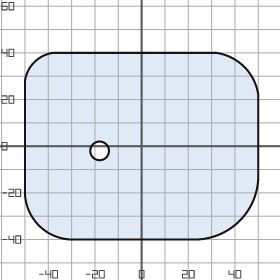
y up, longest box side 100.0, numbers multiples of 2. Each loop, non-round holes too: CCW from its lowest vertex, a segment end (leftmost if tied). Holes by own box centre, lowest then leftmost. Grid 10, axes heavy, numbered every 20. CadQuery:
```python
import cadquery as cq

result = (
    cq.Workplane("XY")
    .moveTo(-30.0, -40.0)
    .lineTo(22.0, -40.0)
    .threePointArc((42.0, -32.0), (50.0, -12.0))
    .lineTo(50.0, 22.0)
    .threePointArc((44.0, 34.0), (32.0, 40.0))
    .lineTo(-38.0, 40.0)
    .threePointArc((-46.0, 36.0), (-50.0, 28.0))
    .lineTo(-50.0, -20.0)
    .threePointArc((-44.0, -34.0), (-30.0, -40.0))
    .close()
    .moveTo(-18.0, -2.0)
    .circle(4.0)
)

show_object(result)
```